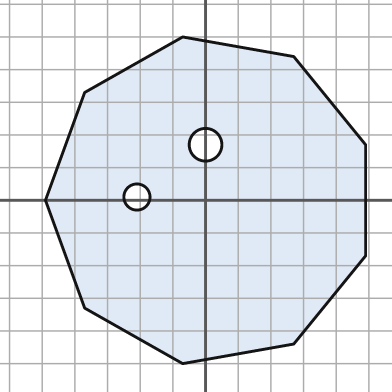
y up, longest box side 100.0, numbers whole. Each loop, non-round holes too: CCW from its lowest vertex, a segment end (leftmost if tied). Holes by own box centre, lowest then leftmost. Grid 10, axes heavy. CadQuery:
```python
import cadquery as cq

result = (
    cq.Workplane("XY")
    .moveTo(-7.0, -50.0)
    .lineTo(27.0, -44.0)
    .lineTo(49.0, -17.0)
    .lineTo(49.0, 17.0)
    .lineTo(27.0, 44.0)
    .lineTo(-7.0, 50.0)
    .lineTo(-37.0, 33.0)
    .lineTo(-49.0, 0.0)
    .lineTo(-37.0, -33.0)
    .close()
    .moveTo(-21.0, 1.0)
    .circle(4.0)
    .moveTo(0.0, 17.0)
    .circle(5.0)
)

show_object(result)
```